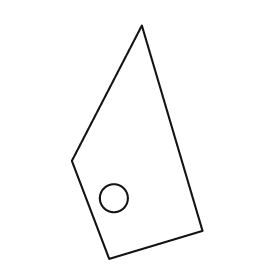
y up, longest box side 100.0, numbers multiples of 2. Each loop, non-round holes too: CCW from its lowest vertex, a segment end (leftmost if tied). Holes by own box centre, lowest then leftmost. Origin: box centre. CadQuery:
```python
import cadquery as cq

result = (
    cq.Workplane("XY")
    .moveTo(-12.0, -50.0)
    .lineTo(28.0, -38.0)
    .lineTo(2.0, 50.0)
    .lineTo(-28.0, -8.0)
    .close()
    .moveTo(-10.0, -24.0)
    .circle(6.0)
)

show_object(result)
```